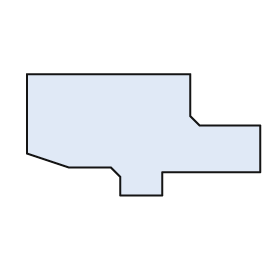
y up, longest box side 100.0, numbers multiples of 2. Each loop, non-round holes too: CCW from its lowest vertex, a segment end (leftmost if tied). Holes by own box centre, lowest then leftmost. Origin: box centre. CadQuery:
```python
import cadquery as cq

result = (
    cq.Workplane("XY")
    .moveTo(-10.0, -26.0)
    .lineTo(8.0, -26.0)
    .lineTo(8.0, -16.0)
    .lineTo(50.0, -16.0)
    .lineTo(50.0, 4.0)
    .lineTo(24.0, 4.0)
    .lineTo(20.0, 8.0)
    .lineTo(20.0, 26.0)
    .lineTo(-50.0, 26.0)
    .lineTo(-50.0, -8.0)
    .lineTo(-32.0, -14.0)
    .lineTo(-14.0, -14.0)
    .lineTo(-10.0, -18.0)
    .close()
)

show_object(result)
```